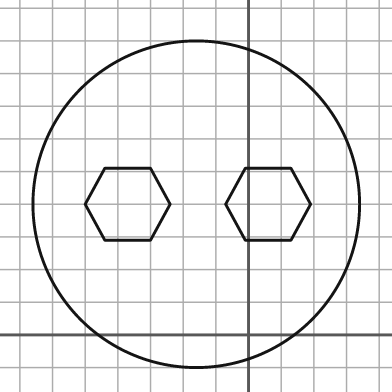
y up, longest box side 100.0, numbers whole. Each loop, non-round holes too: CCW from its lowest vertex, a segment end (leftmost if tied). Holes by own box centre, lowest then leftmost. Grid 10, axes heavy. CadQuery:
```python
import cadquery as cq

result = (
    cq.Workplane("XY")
    .moveTo(-16.0, 40.0)
    .circle(50.0)
    .moveTo(-44.0, 29.0)
    .lineTo(-30.0, 29.0)
    .lineTo(-24.0, 40.0)
    .lineTo(-30.0, 51.0)
    .lineTo(-44.0, 51.0)
    .lineTo(-50.0, 40.0)
    .close()
    .moveTo(-1.0, 29.0)
    .lineTo(13.0, 29.0)
    .lineTo(19.0, 40.0)
    .lineTo(13.0, 51.0)
    .lineTo(-1.0, 51.0)
    .lineTo(-7.0, 40.0)
    .close()
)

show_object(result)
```